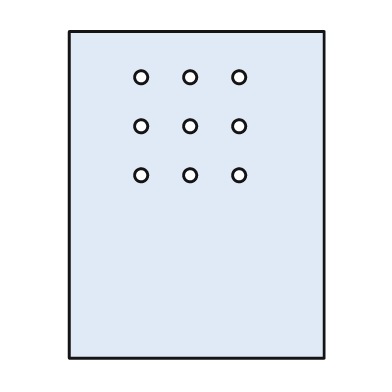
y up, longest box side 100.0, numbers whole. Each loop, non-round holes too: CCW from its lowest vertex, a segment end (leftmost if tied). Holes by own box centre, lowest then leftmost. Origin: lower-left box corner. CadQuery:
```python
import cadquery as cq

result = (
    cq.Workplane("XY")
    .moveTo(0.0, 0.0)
    .lineTo(78.0, 0.0)
    .lineTo(78.0, 100.0)
    .lineTo(0.0, 100.0)
    .close()
    .moveTo(22.0, 56.0)
    .circle(2.0)
    .moveTo(37.0, 56.0)
    .circle(2.0)
    .moveTo(52.0, 56.0)
    .circle(2.0)
    .moveTo(22.0, 71.0)
    .circle(2.0)
    .moveTo(37.0, 71.0)
    .circle(2.0)
    .moveTo(52.0, 71.0)
    .circle(2.0)
    .moveTo(22.0, 86.0)
    .circle(2.0)
    .moveTo(37.0, 86.0)
    .circle(2.0)
    .moveTo(52.0, 86.0)
    .circle(2.0)
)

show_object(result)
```